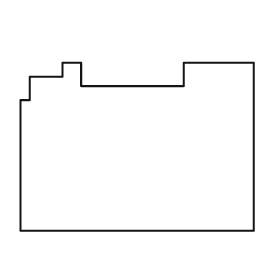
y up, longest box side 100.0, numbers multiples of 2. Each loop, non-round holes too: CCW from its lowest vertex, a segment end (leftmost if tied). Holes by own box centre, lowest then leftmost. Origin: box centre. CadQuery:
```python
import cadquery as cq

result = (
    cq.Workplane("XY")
    .moveTo(-50.0, -36.0)
    .lineTo(50.0, -36.0)
    .lineTo(50.0, 36.0)
    .lineTo(20.0, 36.0)
    .lineTo(20.0, 26.0)
    .lineTo(-24.0, 26.0)
    .lineTo(-24.0, 36.0)
    .lineTo(-32.0, 36.0)
    .lineTo(-32.0, 30.0)
    .lineTo(-46.0, 30.0)
    .lineTo(-46.0, 20.0)
    .lineTo(-50.0, 20.0)
    .close()
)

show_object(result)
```